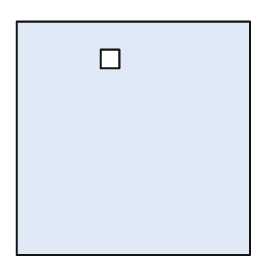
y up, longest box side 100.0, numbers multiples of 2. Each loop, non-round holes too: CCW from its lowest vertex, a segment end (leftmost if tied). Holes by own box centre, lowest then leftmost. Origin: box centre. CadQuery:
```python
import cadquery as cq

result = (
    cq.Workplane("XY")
    .moveTo(-50.0, -50.0)
    .lineTo(50.0, -50.0)
    .lineTo(50.0, 50.0)
    .lineTo(-50.0, 50.0)
    .close()
    .moveTo(-14.0, 30.0)
    .lineTo(-6.0, 30.0)
    .lineTo(-6.0, 38.0)
    .lineTo(-14.0, 38.0)
    .close()
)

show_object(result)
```